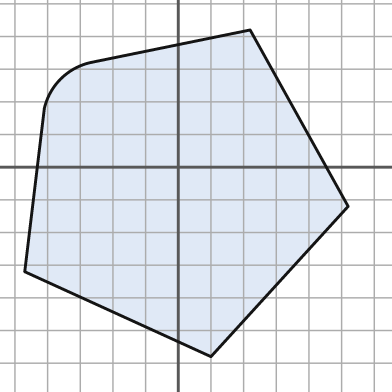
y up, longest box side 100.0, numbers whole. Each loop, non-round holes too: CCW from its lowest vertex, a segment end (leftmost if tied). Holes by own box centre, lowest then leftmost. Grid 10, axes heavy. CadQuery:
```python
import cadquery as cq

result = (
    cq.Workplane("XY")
    .moveTo(10.0, -58.0)
    .lineTo(52.0, -12.0)
    .lineTo(22.0, 42.0)
    .lineTo(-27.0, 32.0)
    .threePointArc((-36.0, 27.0), (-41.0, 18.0))
    .lineTo(-47.0, -32.0)
    .close()
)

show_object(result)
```